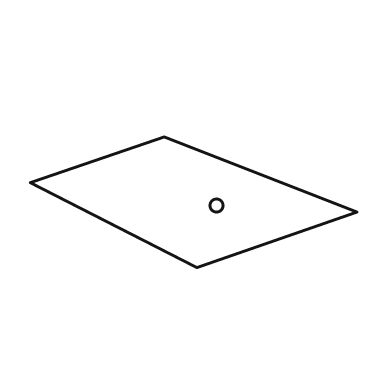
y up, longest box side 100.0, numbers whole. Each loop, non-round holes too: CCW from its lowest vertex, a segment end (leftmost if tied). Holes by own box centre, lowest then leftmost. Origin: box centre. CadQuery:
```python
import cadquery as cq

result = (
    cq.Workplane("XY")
    .moveTo(1.0, -20.0)
    .lineTo(50.0, -3.0)
    .lineTo(-9.0, 20.0)
    .lineTo(-50.0, 6.0)
    .close()
    .moveTo(7.0, -1.0)
    .circle(2.0)
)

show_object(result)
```